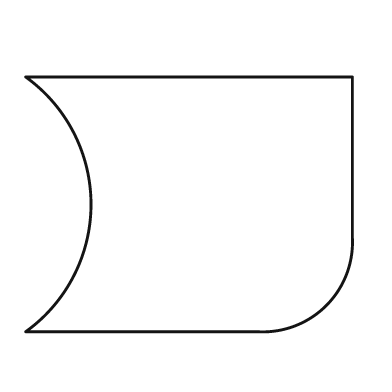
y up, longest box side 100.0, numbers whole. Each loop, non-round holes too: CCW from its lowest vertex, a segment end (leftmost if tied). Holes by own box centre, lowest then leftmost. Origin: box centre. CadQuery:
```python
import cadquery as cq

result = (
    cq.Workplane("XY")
    .moveTo(-50.0, -39.0)
    .lineTo(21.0, -39.0)
    .threePointArc((42.0, -31.0), (50.0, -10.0))
    .lineTo(50.0, 39.0)
    .lineTo(-50.0, 39.0)
    .threePointArc((-30.0, 0.0), (-50.0, -39.0))
    .close()
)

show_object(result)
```